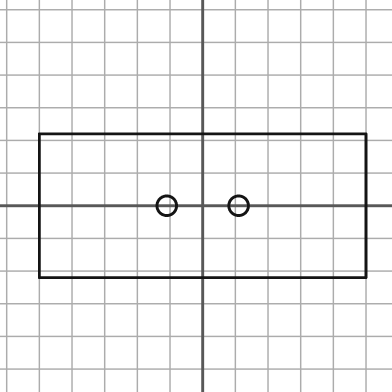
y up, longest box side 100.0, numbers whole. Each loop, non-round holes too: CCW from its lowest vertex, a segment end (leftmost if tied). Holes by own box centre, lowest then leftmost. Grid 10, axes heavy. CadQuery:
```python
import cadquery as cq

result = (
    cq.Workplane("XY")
    .moveTo(-50.0, -22.0)
    .lineTo(50.0, -22.0)
    .lineTo(50.0, 22.0)
    .lineTo(-50.0, 22.0)
    .close()
    .moveTo(-11.0, 0.0)
    .circle(3.0)
    .moveTo(11.0, 0.0)
    .circle(3.0)
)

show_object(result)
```